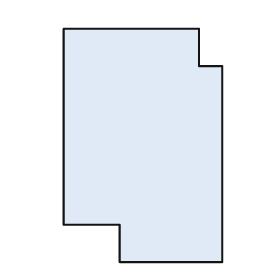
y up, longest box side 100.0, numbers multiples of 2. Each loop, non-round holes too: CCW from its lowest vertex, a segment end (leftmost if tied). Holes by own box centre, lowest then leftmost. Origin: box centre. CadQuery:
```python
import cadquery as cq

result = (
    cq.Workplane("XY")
    .moveTo(-10.0, -50.0)
    .lineTo(34.0, -50.0)
    .lineTo(34.0, 34.0)
    .lineTo(24.0, 34.0)
    .lineTo(24.0, 50.0)
    .lineTo(-34.0, 50.0)
    .lineTo(-34.0, -34.0)
    .lineTo(-10.0, -34.0)
    .close()
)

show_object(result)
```